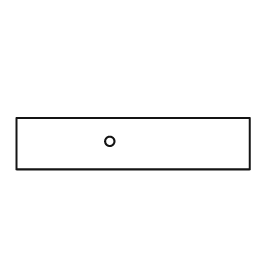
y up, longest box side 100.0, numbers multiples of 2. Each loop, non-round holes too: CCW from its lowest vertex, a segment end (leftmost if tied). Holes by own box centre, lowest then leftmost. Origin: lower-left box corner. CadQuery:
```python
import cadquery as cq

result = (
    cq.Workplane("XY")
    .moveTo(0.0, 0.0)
    .lineTo(100.0, 0.0)
    .lineTo(100.0, 22.0)
    .lineTo(0.0, 22.0)
    .close()
    .moveTo(40.0, 12.0)
    .circle(2.0)
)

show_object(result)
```